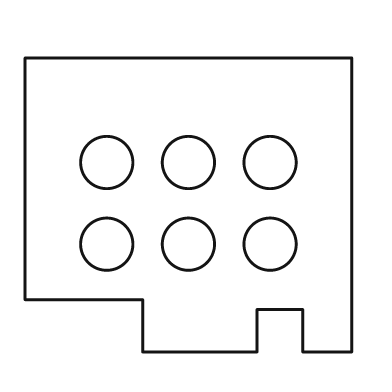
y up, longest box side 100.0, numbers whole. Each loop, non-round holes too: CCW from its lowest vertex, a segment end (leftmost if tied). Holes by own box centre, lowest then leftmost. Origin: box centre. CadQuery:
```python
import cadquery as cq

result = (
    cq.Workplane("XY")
    .moveTo(-14.0, -45.0)
    .lineTo(21.0, -45.0)
    .lineTo(21.0, -32.0)
    .lineTo(35.0, -32.0)
    .lineTo(35.0, -45.0)
    .lineTo(50.0, -45.0)
    .lineTo(50.0, 45.0)
    .lineTo(-50.0, 45.0)
    .lineTo(-50.0, -29.0)
    .lineTo(-14.0, -29.0)
    .close()
    .moveTo(-25.0, -12.0)
    .circle(8.0)
    .moveTo(0.0, -12.0)
    .circle(8.0)
    .moveTo(25.0, -12.0)
    .circle(8.0)
    .moveTo(-25.0, 13.0)
    .circle(8.0)
    .moveTo(0.0, 13.0)
    .circle(8.0)
    .moveTo(25.0, 13.0)
    .circle(8.0)
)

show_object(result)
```